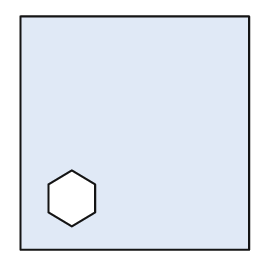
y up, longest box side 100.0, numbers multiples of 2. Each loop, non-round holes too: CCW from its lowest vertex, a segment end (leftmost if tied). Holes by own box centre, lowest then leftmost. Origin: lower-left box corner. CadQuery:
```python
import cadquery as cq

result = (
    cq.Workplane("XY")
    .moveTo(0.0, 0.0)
    .lineTo(98.0, 0.0)
    .lineTo(98.0, 100.0)
    .lineTo(0.0, 100.0)
    .close()
    .moveTo(22.0, 10.0)
    .lineTo(32.0, 16.0)
    .lineTo(32.0, 28.0)
    .lineTo(22.0, 34.0)
    .lineTo(12.0, 28.0)
    .lineTo(12.0, 16.0)
    .close()
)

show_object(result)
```